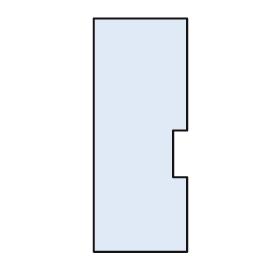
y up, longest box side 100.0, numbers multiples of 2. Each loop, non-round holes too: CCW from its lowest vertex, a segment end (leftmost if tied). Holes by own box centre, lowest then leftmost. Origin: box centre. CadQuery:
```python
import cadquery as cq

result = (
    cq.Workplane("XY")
    .moveTo(-20.0, -50.0)
    .lineTo(20.0, -50.0)
    .lineTo(20.0, -18.0)
    .lineTo(14.0, -18.0)
    .lineTo(14.0, 2.0)
    .lineTo(20.0, 2.0)
    .lineTo(20.0, 50.0)
    .lineTo(-20.0, 50.0)
    .close()
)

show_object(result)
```